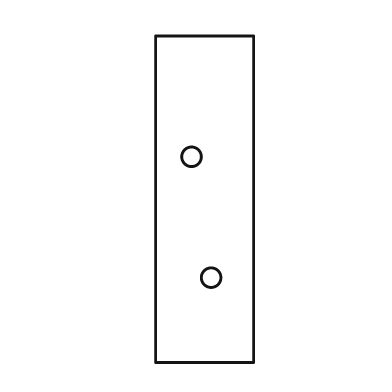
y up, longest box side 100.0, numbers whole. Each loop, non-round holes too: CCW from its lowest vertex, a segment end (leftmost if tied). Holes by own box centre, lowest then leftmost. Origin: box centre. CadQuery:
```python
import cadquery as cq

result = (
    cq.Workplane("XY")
    .moveTo(-15.0, -50.0)
    .lineTo(15.0, -50.0)
    .lineTo(15.0, 50.0)
    .lineTo(-15.0, 50.0)
    .close()
    .moveTo(2.0, -24.0)
    .circle(3.0)
    .moveTo(-4.0, 13.0)
    .circle(3.0)
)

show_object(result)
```